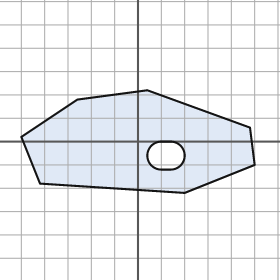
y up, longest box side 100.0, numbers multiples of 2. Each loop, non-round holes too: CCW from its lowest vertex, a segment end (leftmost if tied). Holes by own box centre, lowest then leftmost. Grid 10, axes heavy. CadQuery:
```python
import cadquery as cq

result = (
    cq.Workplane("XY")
    .moveTo(20.0, -22.0)
    .lineTo(50.0, -10.0)
    .lineTo(48.0, 6.0)
    .lineTo(4.0, 22.0)
    .lineTo(-26.0, 18.0)
    .lineTo(-50.0, 2.0)
    .lineTo(-42.0, -18.0)
    .close()
    .moveTo(10.0, -12.0)
    .lineTo(14.0, -12.0)
    .threePointArc((20.0, -6.0), (14.0, 0.0))
    .lineTo(10.0, 0.0)
    .threePointArc((4.0, -6.0), (10.0, -12.0))
    .close()
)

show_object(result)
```